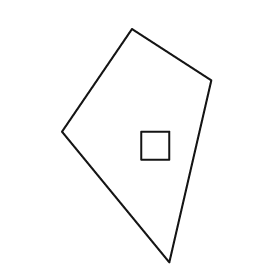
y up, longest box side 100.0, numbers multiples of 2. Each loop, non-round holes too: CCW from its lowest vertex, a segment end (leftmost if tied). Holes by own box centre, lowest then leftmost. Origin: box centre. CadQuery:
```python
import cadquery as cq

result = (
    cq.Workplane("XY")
    .moveTo(14.0, -50.0)
    .lineTo(32.0, 28.0)
    .lineTo(-2.0, 50.0)
    .lineTo(-32.0, 6.0)
    .close()
    .moveTo(2.0, -6.0)
    .lineTo(14.0, -6.0)
    .lineTo(14.0, 6.0)
    .lineTo(2.0, 6.0)
    .close()
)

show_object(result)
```